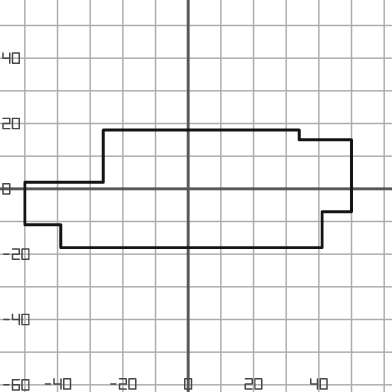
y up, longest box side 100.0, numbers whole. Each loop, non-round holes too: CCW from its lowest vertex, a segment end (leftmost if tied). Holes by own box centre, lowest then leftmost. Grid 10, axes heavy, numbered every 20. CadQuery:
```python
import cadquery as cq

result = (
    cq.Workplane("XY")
    .moveTo(-39.0, -18.0)
    .lineTo(41.0, -18.0)
    .lineTo(41.0, -7.0)
    .lineTo(50.0, -7.0)
    .lineTo(50.0, 15.0)
    .lineTo(34.0, 15.0)
    .lineTo(34.0, 18.0)
    .lineTo(-26.0, 18.0)
    .lineTo(-26.0, 2.0)
    .lineTo(-50.0, 2.0)
    .lineTo(-50.0, -11.0)
    .lineTo(-39.0, -11.0)
    .close()
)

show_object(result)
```